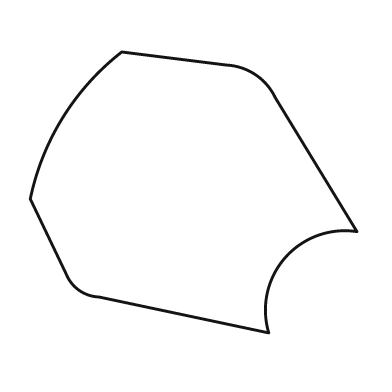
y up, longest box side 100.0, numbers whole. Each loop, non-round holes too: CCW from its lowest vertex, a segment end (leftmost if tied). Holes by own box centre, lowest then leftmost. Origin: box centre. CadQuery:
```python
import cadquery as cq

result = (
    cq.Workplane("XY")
    .moveTo(23.0, -43.0)
    .threePointArc((28.0, -20.0), (50.0, -12.0))
    .lineTo(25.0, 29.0)
    .threePointArc((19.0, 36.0), (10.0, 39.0))
    .lineTo(-22.0, 43.0)
    .threePointArc((-40.0, 23.0), (-50.0, -2.0))
    .lineTo(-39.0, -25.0)
    .threePointArc((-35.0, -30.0), (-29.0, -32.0))
    .close()
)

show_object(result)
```